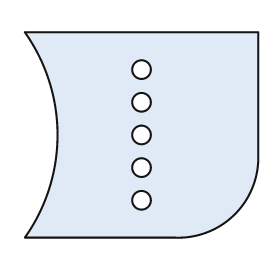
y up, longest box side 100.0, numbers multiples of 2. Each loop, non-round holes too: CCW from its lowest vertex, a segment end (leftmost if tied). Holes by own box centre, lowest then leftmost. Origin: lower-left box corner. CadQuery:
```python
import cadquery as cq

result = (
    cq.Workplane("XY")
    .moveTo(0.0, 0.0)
    .lineTo(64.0, 0.0)
    .threePointArc((90.0, 10.0), (100.0, 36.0))
    .lineTo(100.0, 88.0)
    .lineTo(0.0, 88.0)
    .threePointArc((14.0, 44.0), (0.0, 0.0))
    .close()
    .moveTo(50.0, 16.0)
    .circle(4.0)
    .moveTo(50.0, 30.0)
    .circle(4.0)
    .moveTo(50.0, 44.0)
    .circle(4.0)
    .moveTo(50.0, 58.0)
    .circle(4.0)
    .moveTo(50.0, 72.0)
    .circle(4.0)
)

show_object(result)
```